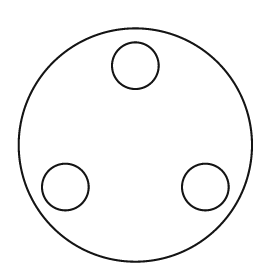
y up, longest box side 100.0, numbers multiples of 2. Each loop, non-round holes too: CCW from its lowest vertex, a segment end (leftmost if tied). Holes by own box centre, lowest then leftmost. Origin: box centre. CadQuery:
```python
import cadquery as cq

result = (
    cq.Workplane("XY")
    .moveTo(0.0, 0.0)
    .circle(50.0)
    .moveTo(-30.0, -18.0)
    .circle(10.0)
    .moveTo(30.0, -18.0)
    .circle(10.0)
    .moveTo(0.0, 34.0)
    .circle(10.0)
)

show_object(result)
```